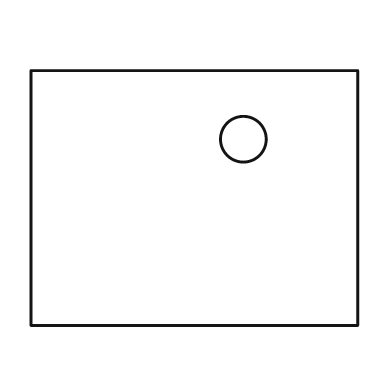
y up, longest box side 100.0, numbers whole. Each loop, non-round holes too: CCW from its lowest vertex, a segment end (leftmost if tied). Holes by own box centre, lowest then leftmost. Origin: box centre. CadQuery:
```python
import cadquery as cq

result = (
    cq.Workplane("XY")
    .moveTo(-50.0, -39.0)
    .lineTo(50.0, -39.0)
    .lineTo(50.0, 39.0)
    .lineTo(-50.0, 39.0)
    .close()
    .moveTo(15.0, 18.0)
    .circle(7.0)
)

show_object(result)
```